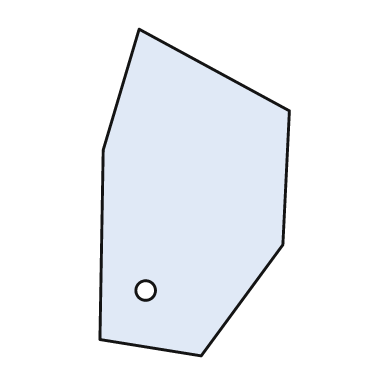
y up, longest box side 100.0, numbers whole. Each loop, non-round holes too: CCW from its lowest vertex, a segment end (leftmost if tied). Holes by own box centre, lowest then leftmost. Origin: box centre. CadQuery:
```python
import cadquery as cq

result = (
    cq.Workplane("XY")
    .moveTo(2.0, -50.0)
    .lineTo(27.0, -16.0)
    .lineTo(29.0, 25.0)
    .lineTo(-17.0, 50.0)
    .lineTo(-28.0, 13.0)
    .lineTo(-29.0, -45.0)
    .close()
    .moveTo(-15.0, -30.0)
    .circle(3.0)
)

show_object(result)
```